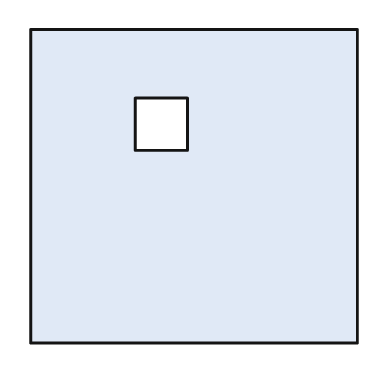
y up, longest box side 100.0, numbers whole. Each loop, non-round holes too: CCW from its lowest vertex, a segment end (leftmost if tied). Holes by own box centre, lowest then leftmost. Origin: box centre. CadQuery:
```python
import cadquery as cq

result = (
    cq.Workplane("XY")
    .moveTo(-50.0, -48.0)
    .lineTo(50.0, -48.0)
    .lineTo(50.0, 48.0)
    .lineTo(-50.0, 48.0)
    .close()
    .moveTo(-18.0, 11.0)
    .lineTo(-2.0, 11.0)
    .lineTo(-2.0, 27.0)
    .lineTo(-18.0, 27.0)
    .close()
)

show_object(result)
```